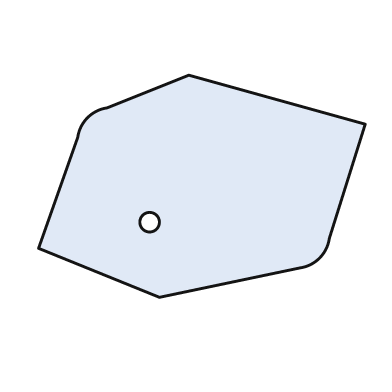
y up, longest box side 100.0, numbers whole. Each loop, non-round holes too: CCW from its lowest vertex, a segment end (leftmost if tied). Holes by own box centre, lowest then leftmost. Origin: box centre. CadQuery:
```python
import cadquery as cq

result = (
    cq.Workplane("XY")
    .moveTo(-13.0, -34.0)
    .lineTo(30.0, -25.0)
    .threePointArc((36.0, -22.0), (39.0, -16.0))
    .lineTo(50.0, 19.0)
    .lineTo(-4.0, 34.0)
    .lineTo(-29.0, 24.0)
    .threePointArc((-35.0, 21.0), (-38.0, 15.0))
    .lineTo(-50.0, -19.0)
    .close()
    .moveTo(-16.0, -11.0)
    .circle(3.0)
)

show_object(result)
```